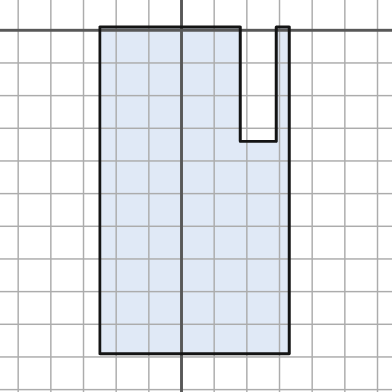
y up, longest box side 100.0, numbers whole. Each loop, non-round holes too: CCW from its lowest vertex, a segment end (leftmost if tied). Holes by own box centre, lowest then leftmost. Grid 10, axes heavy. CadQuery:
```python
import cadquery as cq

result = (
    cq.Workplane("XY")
    .moveTo(-25.0, -99.0)
    .lineTo(33.0, -99.0)
    .lineTo(33.0, 1.0)
    .lineTo(29.0, 1.0)
    .lineTo(29.0, -34.0)
    .lineTo(18.0, -34.0)
    .lineTo(18.0, 1.0)
    .lineTo(-25.0, 1.0)
    .close()
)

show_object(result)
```